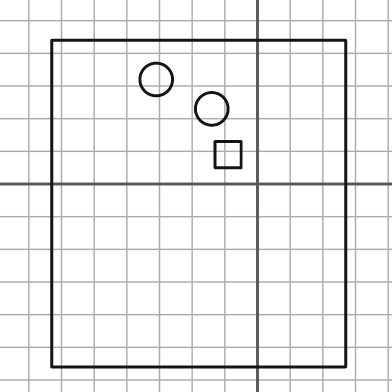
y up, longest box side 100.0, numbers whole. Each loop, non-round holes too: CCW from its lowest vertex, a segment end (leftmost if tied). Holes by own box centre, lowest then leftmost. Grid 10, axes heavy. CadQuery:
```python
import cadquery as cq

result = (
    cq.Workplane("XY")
    .moveTo(-63.0, -56.0)
    .lineTo(27.0, -56.0)
    .lineTo(27.0, 44.0)
    .lineTo(-63.0, 44.0)
    .close()
    .moveTo(-13.0, 5.0)
    .lineTo(-5.0, 5.0)
    .lineTo(-5.0, 13.0)
    .lineTo(-13.0, 13.0)
    .close()
    .moveTo(-14.0, 23.0)
    .circle(5.0)
    .moveTo(-31.0, 32.0)
    .circle(5.0)
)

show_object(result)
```